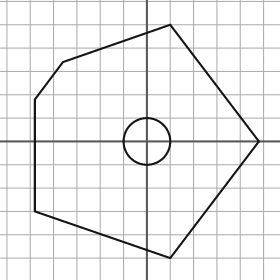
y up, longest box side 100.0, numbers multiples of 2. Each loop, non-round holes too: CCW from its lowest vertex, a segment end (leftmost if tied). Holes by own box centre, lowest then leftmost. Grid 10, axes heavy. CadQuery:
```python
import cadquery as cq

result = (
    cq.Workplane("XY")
    .moveTo(10.0, -50.0)
    .lineTo(48.0, 0.0)
    .lineTo(10.0, 50.0)
    .lineTo(-36.0, 34.0)
    .lineTo(-48.0, 18.0)
    .lineTo(-48.0, -30.0)
    .close()
    .moveTo(0.0, 0.0)
    .circle(10.0)
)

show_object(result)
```